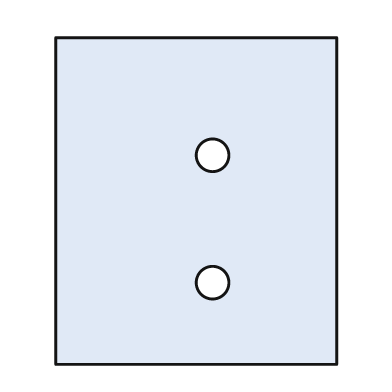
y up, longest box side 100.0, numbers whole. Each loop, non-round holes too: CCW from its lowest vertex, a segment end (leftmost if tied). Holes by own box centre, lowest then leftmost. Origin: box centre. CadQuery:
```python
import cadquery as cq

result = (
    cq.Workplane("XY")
    .moveTo(-43.0, -50.0)
    .lineTo(43.0, -50.0)
    .lineTo(43.0, 50.0)
    .lineTo(-43.0, 50.0)
    .close()
    .moveTo(5.0, -25.0)
    .circle(5.0)
    .moveTo(5.0, 14.0)
    .circle(5.0)
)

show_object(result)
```